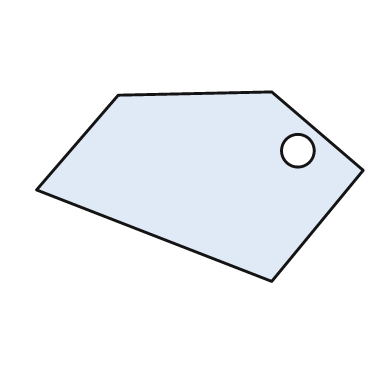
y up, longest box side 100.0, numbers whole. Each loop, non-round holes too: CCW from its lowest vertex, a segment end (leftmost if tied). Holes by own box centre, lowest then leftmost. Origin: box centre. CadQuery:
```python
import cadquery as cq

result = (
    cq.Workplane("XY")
    .moveTo(22.0, -29.0)
    .lineTo(50.0, 5.0)
    .lineTo(22.0, 29.0)
    .lineTo(-25.0, 28.0)
    .lineTo(-50.0, -1.0)
    .close()
    .moveTo(30.0, 11.0)
    .circle(5.0)
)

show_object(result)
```